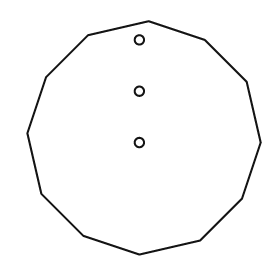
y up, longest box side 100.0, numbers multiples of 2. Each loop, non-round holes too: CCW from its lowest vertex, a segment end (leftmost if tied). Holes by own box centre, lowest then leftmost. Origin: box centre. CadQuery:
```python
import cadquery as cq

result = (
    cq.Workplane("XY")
    .moveTo(-2.0, -50.0)
    .lineTo(24.0, -44.0)
    .lineTo(42.0, -26.0)
    .lineTo(50.0, -2.0)
    .lineTo(44.0, 24.0)
    .lineTo(26.0, 42.0)
    .lineTo(2.0, 50.0)
    .lineTo(-24.0, 44.0)
    .lineTo(-42.0, 26.0)
    .lineTo(-50.0, 2.0)
    .lineTo(-44.0, -24.0)
    .lineTo(-26.0, -42.0)
    .close()
    .moveTo(-2.0, -2.0)
    .circle(2.0)
    .moveTo(-2.0, 20.0)
    .circle(2.0)
    .moveTo(-2.0, 42.0)
    .circle(2.0)
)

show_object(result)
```